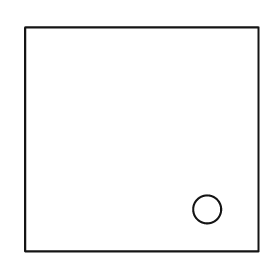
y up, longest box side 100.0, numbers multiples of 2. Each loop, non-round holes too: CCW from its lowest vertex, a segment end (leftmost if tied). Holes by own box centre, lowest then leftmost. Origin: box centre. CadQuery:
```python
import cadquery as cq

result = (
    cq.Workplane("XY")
    .moveTo(-50.0, -48.0)
    .lineTo(50.0, -48.0)
    .lineTo(50.0, 48.0)
    .lineTo(-50.0, 48.0)
    .close()
    .moveTo(28.0, -30.0)
    .circle(6.0)
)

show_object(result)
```